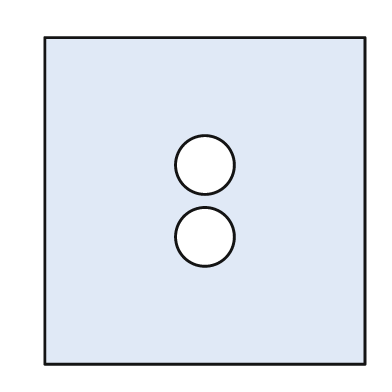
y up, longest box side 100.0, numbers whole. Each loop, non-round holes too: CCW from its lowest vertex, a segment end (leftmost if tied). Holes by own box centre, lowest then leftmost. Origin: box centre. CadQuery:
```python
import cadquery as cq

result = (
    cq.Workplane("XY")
    .moveTo(-49.0, -50.0)
    .lineTo(49.0, -50.0)
    .lineTo(49.0, 50.0)
    .lineTo(-49.0, 50.0)
    .close()
    .moveTo(0.0, -11.0)
    .circle(9.0)
    .moveTo(0.0, 11.0)
    .circle(9.0)
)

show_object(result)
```